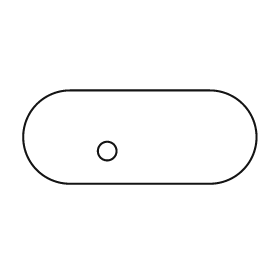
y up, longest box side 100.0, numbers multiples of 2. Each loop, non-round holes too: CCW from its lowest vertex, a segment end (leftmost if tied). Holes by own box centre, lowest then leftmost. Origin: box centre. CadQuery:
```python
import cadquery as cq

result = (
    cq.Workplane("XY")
    .moveTo(-30.0, -20.0)
    .lineTo(30.0, -20.0)
    .threePointArc((50.0, 0.0), (30.0, 20.0))
    .lineTo(-30.0, 20.0)
    .threePointArc((-50.0, 0.0), (-30.0, -20.0))
    .close()
    .moveTo(-14.0, -6.0)
    .circle(4.0)
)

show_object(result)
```